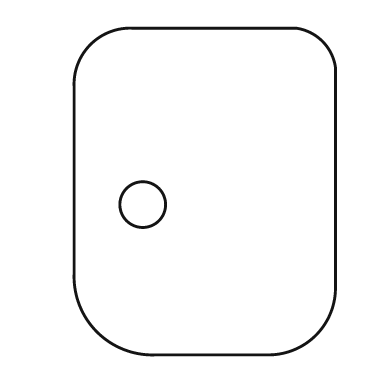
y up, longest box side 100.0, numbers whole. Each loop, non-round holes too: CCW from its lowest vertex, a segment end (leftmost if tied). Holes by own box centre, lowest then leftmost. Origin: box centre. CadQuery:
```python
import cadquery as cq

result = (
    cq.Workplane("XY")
    .moveTo(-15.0, -50.0)
    .lineTo(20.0, -50.0)
    .threePointArc((34.0, -44.0), (40.0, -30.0))
    .lineTo(40.0, 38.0)
    .threePointArc((36.0, 46.0), (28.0, 50.0))
    .lineTo(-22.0, 50.0)
    .threePointArc((-35.0, 45.0), (-40.0, 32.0))
    .lineTo(-40.0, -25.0)
    .threePointArc((-33.0, -43.0), (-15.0, -50.0))
    .close()
    .moveTo(-19.0, -4.0)
    .circle(7.0)
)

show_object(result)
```